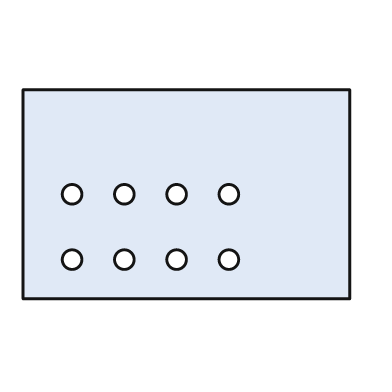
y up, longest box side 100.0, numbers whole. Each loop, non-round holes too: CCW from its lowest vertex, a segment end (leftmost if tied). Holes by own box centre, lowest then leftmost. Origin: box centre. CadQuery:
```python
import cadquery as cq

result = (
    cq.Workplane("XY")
    .moveTo(-50.0, -32.0)
    .lineTo(50.0, -32.0)
    .lineTo(50.0, 32.0)
    .lineTo(-50.0, 32.0)
    .close()
    .moveTo(-35.0, -20.0)
    .circle(3.0)
    .moveTo(-19.0, -20.0)
    .circle(3.0)
    .moveTo(-3.0, -20.0)
    .circle(3.0)
    .moveTo(13.0, -20.0)
    .circle(3.0)
    .moveTo(-35.0, 0.0)
    .circle(3.0)
    .moveTo(-19.0, 0.0)
    .circle(3.0)
    .moveTo(-3.0, 0.0)
    .circle(3.0)
    .moveTo(13.0, 0.0)
    .circle(3.0)
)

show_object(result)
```